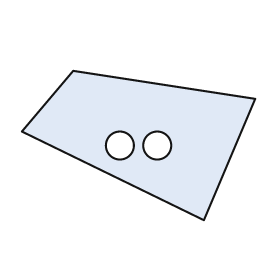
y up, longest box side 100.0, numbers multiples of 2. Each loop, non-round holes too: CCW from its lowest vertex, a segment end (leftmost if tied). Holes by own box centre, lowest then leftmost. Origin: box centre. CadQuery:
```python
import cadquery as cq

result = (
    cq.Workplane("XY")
    .moveTo(28.0, -32.0)
    .lineTo(50.0, 20.0)
    .lineTo(-28.0, 32.0)
    .lineTo(-50.0, 6.0)
    .close()
    .moveTo(-8.0, 0.0)
    .circle(6.0)
    .moveTo(8.0, 0.0)
    .circle(6.0)
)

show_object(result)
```